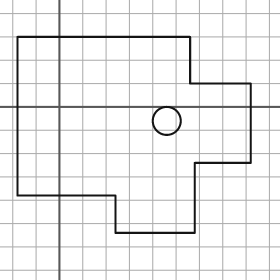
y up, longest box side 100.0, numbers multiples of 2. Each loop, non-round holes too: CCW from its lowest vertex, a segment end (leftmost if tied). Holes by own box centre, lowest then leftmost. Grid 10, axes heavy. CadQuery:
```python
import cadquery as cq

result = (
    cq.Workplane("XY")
    .moveTo(24.0, -54.0)
    .lineTo(58.0, -54.0)
    .lineTo(58.0, -24.0)
    .lineTo(82.0, -24.0)
    .lineTo(82.0, 10.0)
    .lineTo(56.0, 10.0)
    .lineTo(56.0, 30.0)
    .lineTo(-18.0, 30.0)
    .lineTo(-18.0, -38.0)
    .lineTo(24.0, -38.0)
    .close()
    .moveTo(46.0, -6.0)
    .circle(6.0)
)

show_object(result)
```